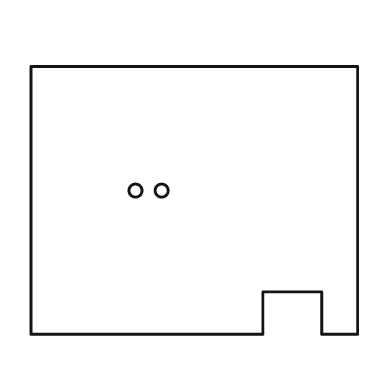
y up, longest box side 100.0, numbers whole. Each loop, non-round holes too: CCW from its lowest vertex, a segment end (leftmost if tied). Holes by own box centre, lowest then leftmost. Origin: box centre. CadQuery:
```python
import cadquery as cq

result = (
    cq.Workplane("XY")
    .moveTo(-50.0, -41.0)
    .lineTo(21.0, -41.0)
    .lineTo(21.0, -28.0)
    .lineTo(39.0, -28.0)
    .lineTo(39.0, -41.0)
    .lineTo(50.0, -41.0)
    .lineTo(50.0, 41.0)
    .lineTo(-50.0, 41.0)
    .close()
    .moveTo(-18.0, 3.0)
    .circle(2.0)
    .moveTo(-10.0, 3.0)
    .circle(2.0)
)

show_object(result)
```